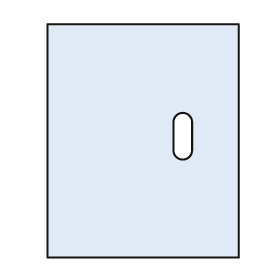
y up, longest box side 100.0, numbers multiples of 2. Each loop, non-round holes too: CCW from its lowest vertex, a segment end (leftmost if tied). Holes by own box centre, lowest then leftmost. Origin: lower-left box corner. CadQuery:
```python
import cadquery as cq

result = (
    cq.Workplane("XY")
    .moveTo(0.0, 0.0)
    .lineTo(82.0, 0.0)
    .lineTo(82.0, 100.0)
    .lineTo(0.0, 100.0)
    .close()
    .moveTo(54.0, 46.0)
    .threePointArc((58.0, 42.0), (62.0, 46.0))
    .lineTo(62.0, 58.0)
    .threePointArc((58.0, 62.0), (54.0, 58.0))
    .close()
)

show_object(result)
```